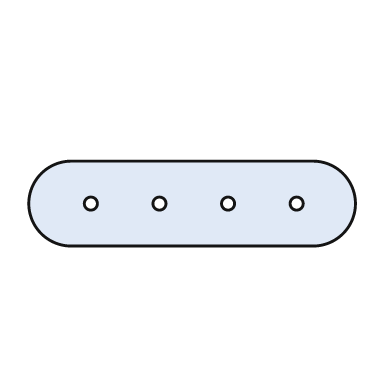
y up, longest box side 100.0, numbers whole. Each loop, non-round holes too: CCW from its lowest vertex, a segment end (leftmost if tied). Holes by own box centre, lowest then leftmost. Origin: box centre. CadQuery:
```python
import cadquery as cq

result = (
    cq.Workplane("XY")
    .moveTo(-37.0, -13.0)
    .lineTo(37.0, -13.0)
    .threePointArc((50.0, 0.0), (37.0, 13.0))
    .lineTo(-37.0, 13.0)
    .threePointArc((-50.0, 0.0), (-37.0, -13.0))
    .close()
    .moveTo(-31.0, 0.0)
    .circle(2.0)
    .moveTo(-10.0, 0.0)
    .circle(2.0)
    .moveTo(11.0, 0.0)
    .circle(2.0)
    .moveTo(32.0, 0.0)
    .circle(2.0)
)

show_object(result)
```